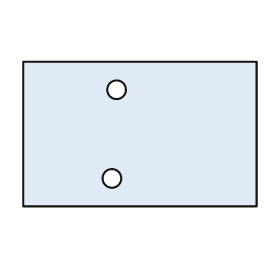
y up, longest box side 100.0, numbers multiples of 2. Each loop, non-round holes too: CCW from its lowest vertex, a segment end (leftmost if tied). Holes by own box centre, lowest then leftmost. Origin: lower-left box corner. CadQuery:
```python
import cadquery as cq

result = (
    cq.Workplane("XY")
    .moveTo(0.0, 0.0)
    .lineTo(100.0, 0.0)
    .lineTo(100.0, 62.0)
    .lineTo(0.0, 62.0)
    .close()
    .moveTo(38.0, 12.0)
    .circle(4.0)
    .moveTo(40.0, 50.0)
    .circle(4.0)
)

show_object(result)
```